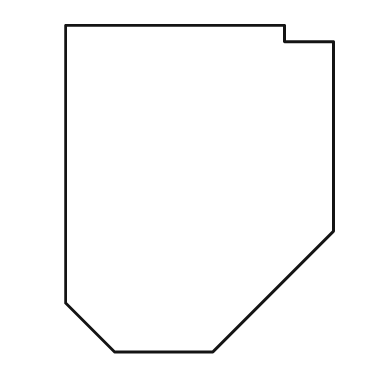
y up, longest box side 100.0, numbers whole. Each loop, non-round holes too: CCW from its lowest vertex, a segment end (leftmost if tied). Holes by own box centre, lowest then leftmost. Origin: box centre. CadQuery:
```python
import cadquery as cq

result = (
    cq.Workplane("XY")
    .moveTo(-26.0, -50.0)
    .lineTo(4.0, -50.0)
    .lineTo(41.0, -13.0)
    .lineTo(41.0, 45.0)
    .lineTo(26.0, 45.0)
    .lineTo(26.0, 50.0)
    .lineTo(-41.0, 50.0)
    .lineTo(-41.0, -35.0)
    .close()
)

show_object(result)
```